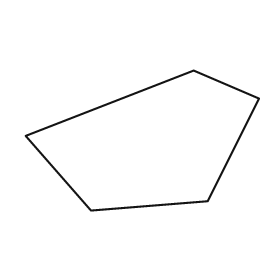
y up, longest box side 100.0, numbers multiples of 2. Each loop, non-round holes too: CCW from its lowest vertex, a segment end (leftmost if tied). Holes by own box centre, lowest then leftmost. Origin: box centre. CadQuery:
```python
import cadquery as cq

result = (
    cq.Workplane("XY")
    .moveTo(-22.0, -30.0)
    .lineTo(28.0, -26.0)
    .lineTo(50.0, 18.0)
    .lineTo(22.0, 30.0)
    .lineTo(-50.0, 2.0)
    .close()
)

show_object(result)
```